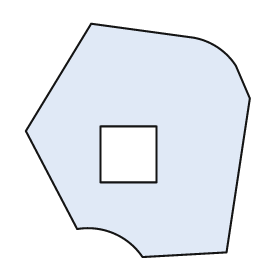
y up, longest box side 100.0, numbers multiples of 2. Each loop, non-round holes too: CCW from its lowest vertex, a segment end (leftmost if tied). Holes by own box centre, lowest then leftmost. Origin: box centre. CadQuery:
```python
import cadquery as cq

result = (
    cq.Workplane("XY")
    .moveTo(2.0, -50.0)
    .lineTo(38.0, -48.0)
    .lineTo(48.0, 18.0)
    .lineTo(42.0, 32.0)
    .threePointArc((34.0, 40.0), (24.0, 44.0))
    .lineTo(-20.0, 50.0)
    .lineTo(-48.0, 4.0)
    .lineTo(-26.0, -38.0)
    .threePointArc((-10.0, -40.0), (2.0, -50.0))
    .close()
    .moveTo(-16.0, -18.0)
    .lineTo(8.0, -18.0)
    .lineTo(8.0, 6.0)
    .lineTo(-16.0, 6.0)
    .close()
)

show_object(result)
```